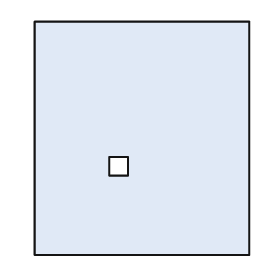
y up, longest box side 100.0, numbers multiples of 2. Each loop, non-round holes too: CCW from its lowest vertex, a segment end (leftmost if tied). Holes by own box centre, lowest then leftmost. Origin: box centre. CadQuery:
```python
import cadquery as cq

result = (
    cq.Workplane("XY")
    .moveTo(-46.0, -50.0)
    .lineTo(46.0, -50.0)
    .lineTo(46.0, 50.0)
    .lineTo(-46.0, 50.0)
    .close()
    .moveTo(-14.0, -16.0)
    .lineTo(-6.0, -16.0)
    .lineTo(-6.0, -8.0)
    .lineTo(-14.0, -8.0)
    .close()
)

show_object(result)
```